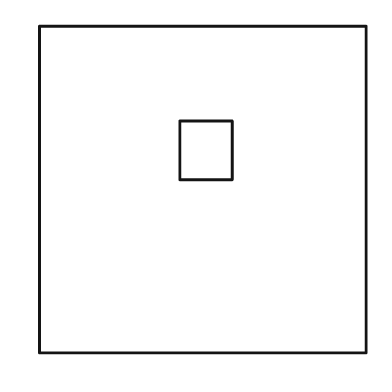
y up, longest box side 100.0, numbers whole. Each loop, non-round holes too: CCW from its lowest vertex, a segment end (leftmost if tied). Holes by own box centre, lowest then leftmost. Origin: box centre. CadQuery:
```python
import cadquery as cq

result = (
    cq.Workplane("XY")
    .moveTo(-50.0, -50.0)
    .lineTo(50.0, -50.0)
    .lineTo(50.0, 50.0)
    .lineTo(-50.0, 50.0)
    .close()
    .moveTo(-7.0, 3.0)
    .lineTo(9.0, 3.0)
    .lineTo(9.0, 21.0)
    .lineTo(-7.0, 21.0)
    .close()
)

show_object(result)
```